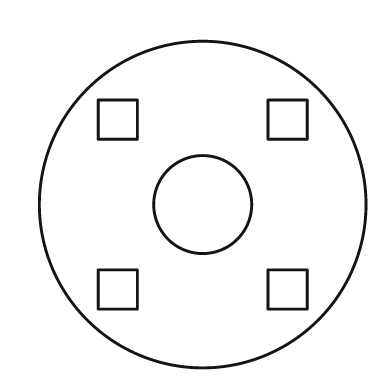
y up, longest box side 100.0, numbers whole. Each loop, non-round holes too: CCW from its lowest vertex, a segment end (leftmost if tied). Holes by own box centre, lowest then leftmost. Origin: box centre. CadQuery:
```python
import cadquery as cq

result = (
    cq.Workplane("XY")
    .moveTo(0.0, 0.0)
    .circle(50.0)
    .moveTo(-32.0, -32.0)
    .lineTo(-20.0, -32.0)
    .lineTo(-20.0, -20.0)
    .lineTo(-32.0, -20.0)
    .close()
    .moveTo(20.0, -32.0)
    .lineTo(32.0, -32.0)
    .lineTo(32.0, -20.0)
    .lineTo(20.0, -20.0)
    .close()
    .moveTo(0.0, 0.0)
    .circle(15.0)
    .moveTo(-32.0, 20.0)
    .lineTo(-20.0, 20.0)
    .lineTo(-20.0, 32.0)
    .lineTo(-32.0, 32.0)
    .close()
    .moveTo(20.0, 20.0)
    .lineTo(32.0, 20.0)
    .lineTo(32.0, 32.0)
    .lineTo(20.0, 32.0)
    .close()
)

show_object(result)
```